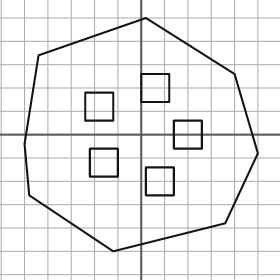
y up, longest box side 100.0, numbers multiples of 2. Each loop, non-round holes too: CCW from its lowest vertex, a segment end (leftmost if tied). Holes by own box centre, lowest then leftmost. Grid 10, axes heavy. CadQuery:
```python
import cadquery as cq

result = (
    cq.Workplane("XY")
    .moveTo(-12.0, -50.0)
    .lineTo(36.0, -38.0)
    .lineTo(50.0, -8.0)
    .lineTo(40.0, 26.0)
    .lineTo(2.0, 50.0)
    .lineTo(-44.0, 34.0)
    .lineTo(-50.0, -4.0)
    .lineTo(-48.0, -26.0)
    .close()
    .moveTo(2.0, -26.0)
    .lineTo(14.0, -26.0)
    .lineTo(14.0, -14.0)
    .lineTo(2.0, -14.0)
    .close()
    .moveTo(-22.0, -18.0)
    .lineTo(-10.0, -18.0)
    .lineTo(-10.0, -6.0)
    .lineTo(-22.0, -6.0)
    .close()
    .moveTo(14.0, -6.0)
    .lineTo(26.0, -6.0)
    .lineTo(26.0, 6.0)
    .lineTo(14.0, 6.0)
    .close()
    .moveTo(-24.0, 6.0)
    .lineTo(-12.0, 6.0)
    .lineTo(-12.0, 18.0)
    .lineTo(-24.0, 18.0)
    .close()
    .moveTo(0.0, 14.0)
    .lineTo(12.0, 14.0)
    .lineTo(12.0, 26.0)
    .lineTo(0.0, 26.0)
    .close()
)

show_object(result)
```